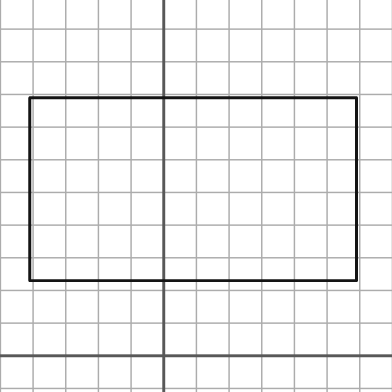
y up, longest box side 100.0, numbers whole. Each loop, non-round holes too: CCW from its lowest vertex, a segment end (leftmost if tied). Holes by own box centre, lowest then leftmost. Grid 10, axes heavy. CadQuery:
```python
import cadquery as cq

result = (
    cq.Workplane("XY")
    .moveTo(-41.0, 23.0)
    .lineTo(59.0, 23.0)
    .lineTo(59.0, 79.0)
    .lineTo(-41.0, 79.0)
    .close()
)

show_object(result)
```